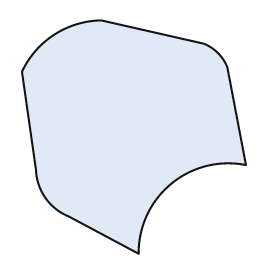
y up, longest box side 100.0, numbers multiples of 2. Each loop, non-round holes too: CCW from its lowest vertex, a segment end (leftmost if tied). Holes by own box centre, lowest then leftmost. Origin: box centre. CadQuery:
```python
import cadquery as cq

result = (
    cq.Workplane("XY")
    .moveTo(2.0, -50.0)
    .threePointArc((16.0, -20.0), (48.0, -12.0))
    .lineTo(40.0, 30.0)
    .threePointArc((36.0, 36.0), (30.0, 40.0))
    .lineTo(-14.0, 50.0)
    .threePointArc((-34.0, 44.0), (-48.0, 28.0))
    .lineTo(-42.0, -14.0)
    .threePointArc((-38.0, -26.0), (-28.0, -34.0))
    .close()
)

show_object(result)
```